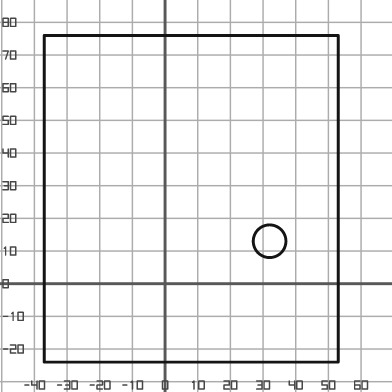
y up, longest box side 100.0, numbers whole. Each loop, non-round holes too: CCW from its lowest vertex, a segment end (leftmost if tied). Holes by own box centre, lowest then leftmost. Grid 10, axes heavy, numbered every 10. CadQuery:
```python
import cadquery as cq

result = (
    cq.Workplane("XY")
    .moveTo(-37.0, -24.0)
    .lineTo(53.0, -24.0)
    .lineTo(53.0, 76.0)
    .lineTo(-37.0, 76.0)
    .close()
    .moveTo(32.0, 13.0)
    .circle(5.0)
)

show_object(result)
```